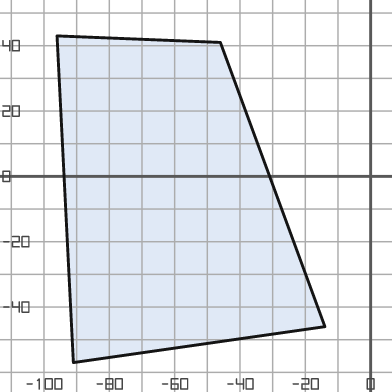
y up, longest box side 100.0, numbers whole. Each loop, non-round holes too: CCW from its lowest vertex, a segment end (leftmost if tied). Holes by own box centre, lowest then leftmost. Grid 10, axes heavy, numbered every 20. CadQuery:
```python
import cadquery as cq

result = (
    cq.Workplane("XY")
    .moveTo(-91.0, -57.0)
    .lineTo(-14.0, -46.0)
    .lineTo(-46.0, 41.0)
    .lineTo(-96.0, 43.0)
    .close()
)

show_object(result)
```